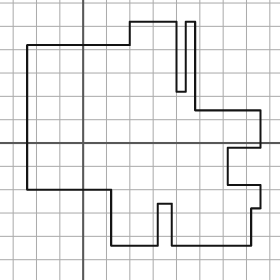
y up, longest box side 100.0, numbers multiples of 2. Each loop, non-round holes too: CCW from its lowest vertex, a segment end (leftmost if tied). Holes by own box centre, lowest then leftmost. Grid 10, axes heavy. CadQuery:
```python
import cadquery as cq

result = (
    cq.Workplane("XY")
    .moveTo(12.0, -44.0)
    .lineTo(32.0, -44.0)
    .lineTo(32.0, -26.0)
    .lineTo(38.0, -26.0)
    .lineTo(38.0, -44.0)
    .lineTo(72.0, -44.0)
    .lineTo(72.0, -28.0)
    .lineTo(76.0, -28.0)
    .lineTo(76.0, -18.0)
    .lineTo(62.0, -18.0)
    .lineTo(62.0, -2.0)
    .lineTo(76.0, -2.0)
    .lineTo(76.0, 14.0)
    .lineTo(48.0, 14.0)
    .lineTo(48.0, 52.0)
    .lineTo(44.0, 52.0)
    .lineTo(44.0, 22.0)
    .lineTo(40.0, 22.0)
    .lineTo(40.0, 52.0)
    .lineTo(20.0, 52.0)
    .lineTo(20.0, 42.0)
    .lineTo(-24.0, 42.0)
    .lineTo(-24.0, -20.0)
    .lineTo(12.0, -20.0)
    .close()
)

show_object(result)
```